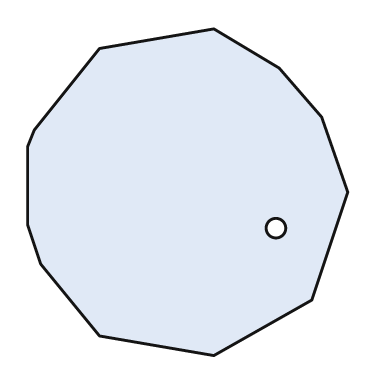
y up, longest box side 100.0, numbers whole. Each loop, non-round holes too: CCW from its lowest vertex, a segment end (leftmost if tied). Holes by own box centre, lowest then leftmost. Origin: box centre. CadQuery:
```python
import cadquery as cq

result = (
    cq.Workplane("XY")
    .moveTo(8.0, -50.0)
    .lineTo(38.0, -33.0)
    .lineTo(49.0, 0.0)
    .lineTo(41.0, 23.0)
    .lineTo(28.0, 38.0)
    .lineTo(8.0, 50.0)
    .lineTo(-27.0, 44.0)
    .lineTo(-47.0, 19.0)
    .lineTo(-49.0, 14.0)
    .lineTo(-49.0, -10.0)
    .lineTo(-45.0, -22.0)
    .lineTo(-27.0, -44.0)
    .close()
    .moveTo(27.0, -11.0)
    .circle(3.0)
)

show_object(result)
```